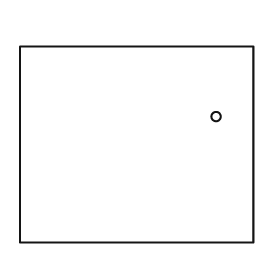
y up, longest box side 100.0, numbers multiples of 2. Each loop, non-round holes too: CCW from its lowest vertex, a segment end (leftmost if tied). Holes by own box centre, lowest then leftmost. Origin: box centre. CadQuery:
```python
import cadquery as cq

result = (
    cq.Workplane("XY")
    .moveTo(-50.0, -42.0)
    .lineTo(50.0, -42.0)
    .lineTo(50.0, 42.0)
    .lineTo(-50.0, 42.0)
    .close()
    .moveTo(34.0, 12.0)
    .circle(2.0)
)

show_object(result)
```